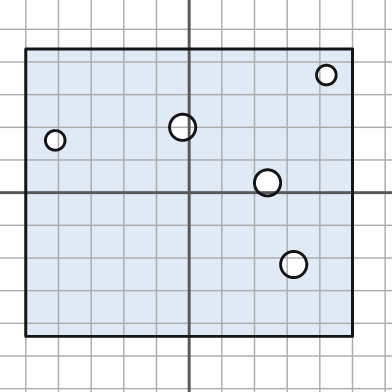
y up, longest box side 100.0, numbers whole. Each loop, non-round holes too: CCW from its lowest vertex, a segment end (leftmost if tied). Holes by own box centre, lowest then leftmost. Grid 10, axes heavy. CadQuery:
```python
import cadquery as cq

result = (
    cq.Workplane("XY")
    .moveTo(-50.0, -44.0)
    .lineTo(50.0, -44.0)
    .lineTo(50.0, 44.0)
    .lineTo(-50.0, 44.0)
    .close()
    .moveTo(32.0, -22.0)
    .circle(4.0)
    .moveTo(24.0, 3.0)
    .circle(4.0)
    .moveTo(-41.0, 16.0)
    .circle(3.0)
    .moveTo(-2.0, 20.0)
    .circle(4.0)
    .moveTo(42.0, 36.0)
    .circle(3.0)
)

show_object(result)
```